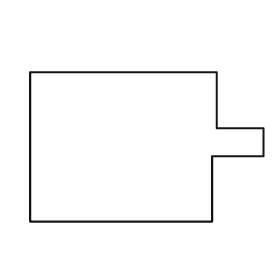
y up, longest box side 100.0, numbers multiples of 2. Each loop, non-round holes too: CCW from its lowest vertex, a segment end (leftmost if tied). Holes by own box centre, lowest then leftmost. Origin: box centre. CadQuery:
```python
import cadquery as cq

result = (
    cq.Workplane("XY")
    .moveTo(-50.0, -32.0)
    .lineTo(28.0, -32.0)
    .lineTo(28.0, -4.0)
    .lineTo(50.0, -4.0)
    .lineTo(50.0, 8.0)
    .lineTo(30.0, 8.0)
    .lineTo(30.0, 32.0)
    .lineTo(-50.0, 32.0)
    .close()
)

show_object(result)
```